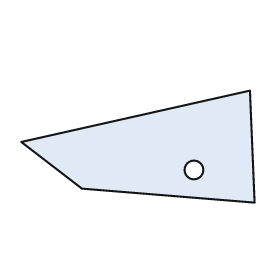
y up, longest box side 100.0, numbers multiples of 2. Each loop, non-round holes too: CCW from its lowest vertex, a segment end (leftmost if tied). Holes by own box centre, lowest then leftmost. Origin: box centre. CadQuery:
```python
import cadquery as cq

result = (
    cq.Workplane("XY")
    .moveTo(50.0, -24.0)
    .lineTo(48.0, 24.0)
    .lineTo(-50.0, 2.0)
    .lineTo(-24.0, -18.0)
    .close()
    .moveTo(24.0, -10.0)
    .circle(4.0)
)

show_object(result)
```